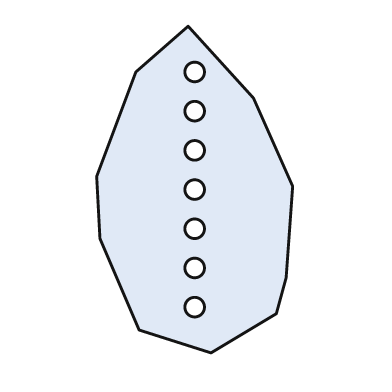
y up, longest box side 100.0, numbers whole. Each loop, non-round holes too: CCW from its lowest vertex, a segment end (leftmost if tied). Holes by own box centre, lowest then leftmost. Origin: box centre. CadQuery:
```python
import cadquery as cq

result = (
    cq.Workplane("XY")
    .moveTo(5.0, -50.0)
    .lineTo(25.0, -38.0)
    .lineTo(28.0, -27.0)
    .lineTo(30.0, 1.0)
    .lineTo(18.0, 28.0)
    .lineTo(-2.0, 50.0)
    .lineTo(-18.0, 36.0)
    .lineTo(-30.0, 4.0)
    .lineTo(-29.0, -15.0)
    .lineTo(-17.0, -43.0)
    .close()
    .moveTo(0.0, -36.0)
    .circle(3.0)
    .moveTo(0.0, -24.0)
    .circle(3.0)
    .moveTo(0.0, -12.0)
    .circle(3.0)
    .moveTo(0.0, 0.0)
    .circle(3.0)
    .moveTo(0.0, 12.0)
    .circle(3.0)
    .moveTo(0.0, 24.0)
    .circle(3.0)
    .moveTo(0.0, 36.0)
    .circle(3.0)
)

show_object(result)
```